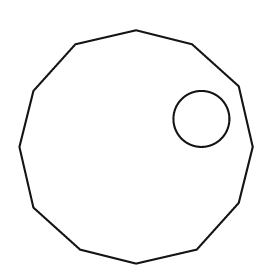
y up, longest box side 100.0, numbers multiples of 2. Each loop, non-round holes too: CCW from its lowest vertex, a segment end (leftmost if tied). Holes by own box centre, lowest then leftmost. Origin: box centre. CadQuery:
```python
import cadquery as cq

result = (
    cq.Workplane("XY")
    .moveTo(0.0, -50.0)
    .lineTo(26.0, -44.0)
    .lineTo(44.0, -24.0)
    .lineTo(50.0, 0.0)
    .lineTo(44.0, 26.0)
    .lineTo(24.0, 44.0)
    .lineTo(0.0, 50.0)
    .lineTo(-26.0, 44.0)
    .lineTo(-44.0, 24.0)
    .lineTo(-50.0, 0.0)
    .lineTo(-44.0, -26.0)
    .lineTo(-24.0, -44.0)
    .close()
    .moveTo(28.0, 12.0)
    .circle(12.0)
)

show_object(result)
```